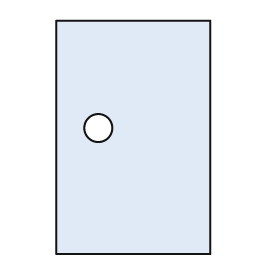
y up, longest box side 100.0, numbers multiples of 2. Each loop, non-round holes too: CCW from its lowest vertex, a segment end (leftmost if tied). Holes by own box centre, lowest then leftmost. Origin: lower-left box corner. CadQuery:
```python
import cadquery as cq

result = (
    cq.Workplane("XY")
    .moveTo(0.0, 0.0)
    .lineTo(66.0, 0.0)
    .lineTo(66.0, 100.0)
    .lineTo(0.0, 100.0)
    .close()
    .moveTo(18.0, 54.0)
    .circle(6.0)
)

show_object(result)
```